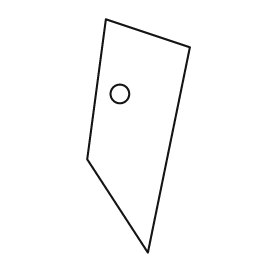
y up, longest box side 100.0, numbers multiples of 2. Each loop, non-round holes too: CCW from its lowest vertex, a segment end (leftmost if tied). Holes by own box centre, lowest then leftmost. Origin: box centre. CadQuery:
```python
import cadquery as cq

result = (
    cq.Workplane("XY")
    .moveTo(4.0, -50.0)
    .lineTo(22.0, 38.0)
    .lineTo(-14.0, 50.0)
    .lineTo(-22.0, -10.0)
    .close()
    .moveTo(-8.0, 18.0)
    .circle(4.0)
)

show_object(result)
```